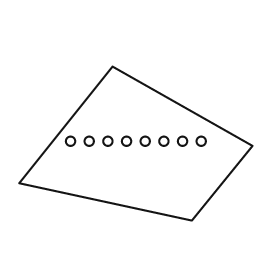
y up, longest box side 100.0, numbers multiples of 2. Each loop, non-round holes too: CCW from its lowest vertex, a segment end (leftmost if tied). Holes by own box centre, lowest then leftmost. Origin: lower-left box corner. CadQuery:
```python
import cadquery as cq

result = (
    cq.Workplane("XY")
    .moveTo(74.0, 0.0)
    .lineTo(100.0, 32.0)
    .lineTo(40.0, 66.0)
    .lineTo(0.0, 16.0)
    .close()
    .moveTo(22.0, 34.0)
    .circle(2.0)
    .moveTo(30.0, 34.0)
    .circle(2.0)
    .moveTo(38.0, 34.0)
    .circle(2.0)
    .moveTo(46.0, 34.0)
    .circle(2.0)
    .moveTo(54.0, 34.0)
    .circle(2.0)
    .moveTo(62.0, 34.0)
    .circle(2.0)
    .moveTo(70.0, 34.0)
    .circle(2.0)
    .moveTo(78.0, 34.0)
    .circle(2.0)
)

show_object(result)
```